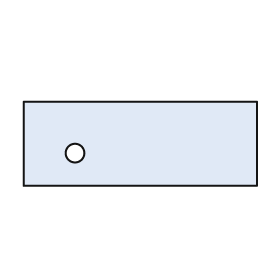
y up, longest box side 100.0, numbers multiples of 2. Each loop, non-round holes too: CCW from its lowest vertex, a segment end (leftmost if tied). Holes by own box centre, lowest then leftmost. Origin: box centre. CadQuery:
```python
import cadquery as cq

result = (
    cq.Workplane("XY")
    .moveTo(-50.0, -18.0)
    .lineTo(50.0, -18.0)
    .lineTo(50.0, 18.0)
    .lineTo(-50.0, 18.0)
    .close()
    .moveTo(-28.0, -4.0)
    .circle(4.0)
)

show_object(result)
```